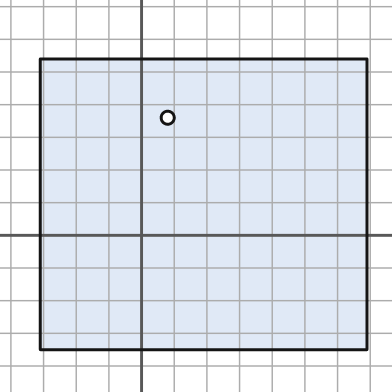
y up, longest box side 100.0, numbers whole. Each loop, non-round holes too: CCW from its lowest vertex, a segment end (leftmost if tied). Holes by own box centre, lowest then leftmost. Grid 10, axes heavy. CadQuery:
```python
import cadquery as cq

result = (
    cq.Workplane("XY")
    .moveTo(-31.0, -35.0)
    .lineTo(69.0, -35.0)
    .lineTo(69.0, 54.0)
    .lineTo(-31.0, 54.0)
    .close()
    .moveTo(8.0, 36.0)
    .circle(2.0)
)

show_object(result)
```